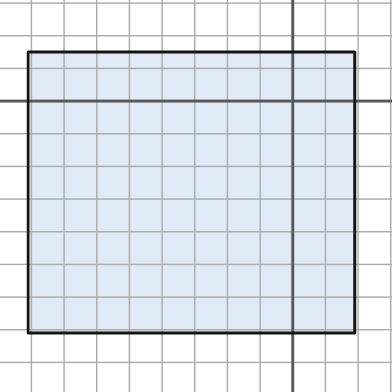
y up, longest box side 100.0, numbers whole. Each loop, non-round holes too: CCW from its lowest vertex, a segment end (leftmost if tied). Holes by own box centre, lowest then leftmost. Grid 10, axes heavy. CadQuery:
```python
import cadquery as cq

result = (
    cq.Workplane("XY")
    .moveTo(-81.0, -71.0)
    .lineTo(19.0, -71.0)
    .lineTo(19.0, 15.0)
    .lineTo(-81.0, 15.0)
    .close()
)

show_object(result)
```